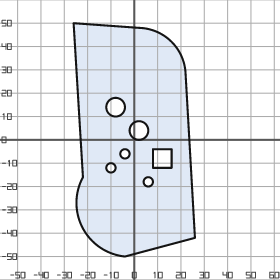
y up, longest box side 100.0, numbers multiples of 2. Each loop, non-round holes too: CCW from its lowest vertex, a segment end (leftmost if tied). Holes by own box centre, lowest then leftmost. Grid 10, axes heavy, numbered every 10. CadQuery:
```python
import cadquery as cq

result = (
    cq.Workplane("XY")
    .moveTo(-4.0, -50.0)
    .lineTo(26.0, -42.0)
    .lineTo(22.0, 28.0)
    .threePointArc((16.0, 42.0), (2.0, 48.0))
    .lineTo(-26.0, 50.0)
    .lineTo(-22.0, -16.0)
    .threePointArc((-22.0, -38.0), (-4.0, -50.0))
    .close()
    .moveTo(6.0, -18.0)
    .circle(2.0)
    .moveTo(-10.0, -12.0)
    .circle(2.0)
    .moveTo(8.0, -12.0)
    .lineTo(16.0, -12.0)
    .lineTo(16.0, -4.0)
    .lineTo(8.0, -4.0)
    .close()
    .moveTo(-4.0, -6.0)
    .circle(2.0)
    .moveTo(2.0, 4.0)
    .circle(4.0)
    .moveTo(-8.0, 14.0)
    .circle(4.0)
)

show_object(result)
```